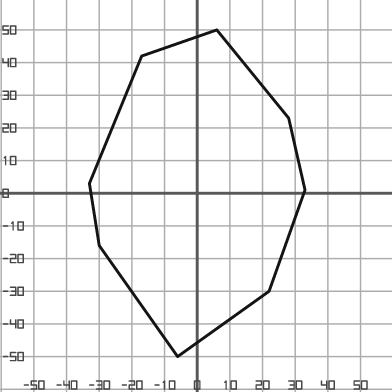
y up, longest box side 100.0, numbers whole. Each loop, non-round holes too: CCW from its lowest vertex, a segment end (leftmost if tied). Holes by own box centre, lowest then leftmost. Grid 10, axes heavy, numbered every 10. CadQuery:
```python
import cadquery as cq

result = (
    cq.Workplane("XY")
    .moveTo(-6.0, -50.0)
    .lineTo(22.0, -30.0)
    .lineTo(33.0, 1.0)
    .lineTo(28.0, 23.0)
    .lineTo(6.0, 50.0)
    .lineTo(-17.0, 42.0)
    .lineTo(-33.0, 3.0)
    .lineTo(-30.0, -16.0)
    .close()
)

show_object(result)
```